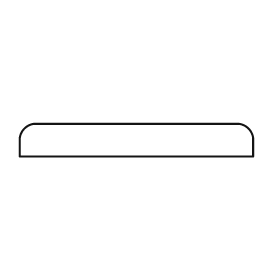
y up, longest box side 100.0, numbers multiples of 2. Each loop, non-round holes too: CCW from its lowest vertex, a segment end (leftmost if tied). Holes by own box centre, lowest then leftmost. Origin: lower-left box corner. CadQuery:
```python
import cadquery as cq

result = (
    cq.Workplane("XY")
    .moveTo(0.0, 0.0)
    .lineTo(100.0, 0.0)
    .lineTo(100.0, 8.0)
    .threePointArc((98.0, 12.0), (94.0, 14.0))
    .lineTo(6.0, 14.0)
    .threePointArc((2.0, 12.0), (0.0, 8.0))
    .close()
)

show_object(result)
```